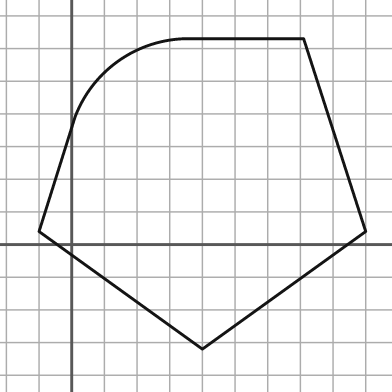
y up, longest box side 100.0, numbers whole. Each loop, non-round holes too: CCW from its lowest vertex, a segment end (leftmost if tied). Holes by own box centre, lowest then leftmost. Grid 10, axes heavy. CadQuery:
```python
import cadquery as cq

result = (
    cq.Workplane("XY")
    .moveTo(40.0, -32.0)
    .lineTo(90.0, 4.0)
    .lineTo(71.0, 63.0)
    .lineTo(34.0, 63.0)
    .threePointArc((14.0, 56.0), (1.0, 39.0))
    .lineTo(-10.0, 4.0)
    .close()
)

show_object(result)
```